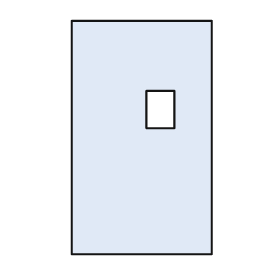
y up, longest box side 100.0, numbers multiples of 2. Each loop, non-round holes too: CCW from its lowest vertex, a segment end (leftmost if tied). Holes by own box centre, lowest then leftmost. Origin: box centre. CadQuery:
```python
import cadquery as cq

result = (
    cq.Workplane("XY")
    .moveTo(-30.0, -50.0)
    .lineTo(30.0, -50.0)
    .lineTo(30.0, 50.0)
    .lineTo(-30.0, 50.0)
    .close()
    .moveTo(2.0, 4.0)
    .lineTo(14.0, 4.0)
    .lineTo(14.0, 20.0)
    .lineTo(2.0, 20.0)
    .close()
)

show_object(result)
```